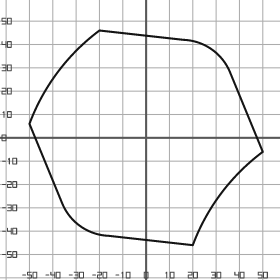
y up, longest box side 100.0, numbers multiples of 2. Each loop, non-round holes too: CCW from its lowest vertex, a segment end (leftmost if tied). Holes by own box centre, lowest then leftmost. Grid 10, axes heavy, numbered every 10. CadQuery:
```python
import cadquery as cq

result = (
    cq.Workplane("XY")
    .moveTo(20.0, -46.0)
    .threePointArc((32.0, -24.0), (50.0, -6.0))
    .lineTo(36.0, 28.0)
    .threePointArc((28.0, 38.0), (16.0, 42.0))
    .lineTo(-20.0, 46.0)
    .threePointArc((-38.0, 28.0), (-50.0, 6.0))
    .lineTo(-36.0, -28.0)
    .threePointArc((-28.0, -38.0), (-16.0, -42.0))
    .close()
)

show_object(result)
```